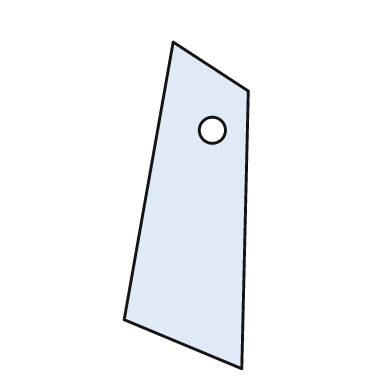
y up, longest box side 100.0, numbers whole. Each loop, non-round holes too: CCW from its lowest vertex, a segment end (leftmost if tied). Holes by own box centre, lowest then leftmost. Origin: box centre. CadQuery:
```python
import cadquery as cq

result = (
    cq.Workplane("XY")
    .moveTo(17.0, -50.0)
    .lineTo(19.0, 35.0)
    .lineTo(-4.0, 50.0)
    .lineTo(-19.0, -35.0)
    .close()
    .moveTo(8.0, 23.0)
    .circle(4.0)
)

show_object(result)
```